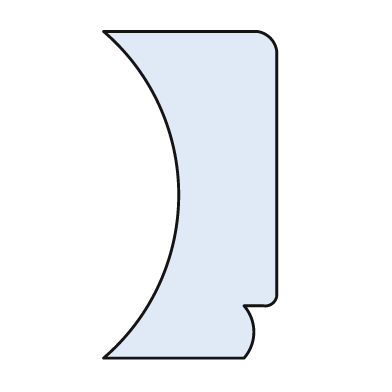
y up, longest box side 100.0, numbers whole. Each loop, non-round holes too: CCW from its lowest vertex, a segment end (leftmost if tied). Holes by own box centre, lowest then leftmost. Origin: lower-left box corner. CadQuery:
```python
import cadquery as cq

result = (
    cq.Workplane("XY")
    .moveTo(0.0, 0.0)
    .lineTo(43.0, 0.0)
    .threePointArc((46.0, 8.0), (43.0, 16.0))
    .lineTo(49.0, 16.0)
    .threePointArc((52.0, 17.0), (53.0, 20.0))
    .lineTo(53.0, 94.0)
    .threePointArc((51.0, 98.0), (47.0, 100.0))
    .lineTo(0.0, 100.0)
    .threePointArc((23.0, 50.0), (0.0, 0.0))
    .close()
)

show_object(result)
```